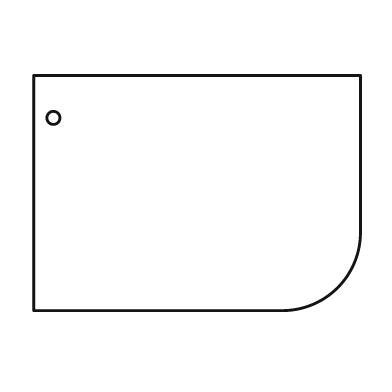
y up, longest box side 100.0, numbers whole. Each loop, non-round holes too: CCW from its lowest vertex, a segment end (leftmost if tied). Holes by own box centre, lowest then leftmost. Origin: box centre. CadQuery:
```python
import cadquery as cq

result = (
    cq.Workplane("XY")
    .moveTo(-50.0, -36.0)
    .lineTo(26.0, -36.0)
    .threePointArc((43.0, -29.0), (50.0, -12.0))
    .lineTo(50.0, 36.0)
    .lineTo(-50.0, 36.0)
    .close()
    .moveTo(-44.0, 23.0)
    .circle(2.0)
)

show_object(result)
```